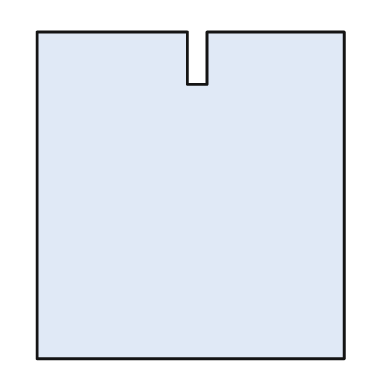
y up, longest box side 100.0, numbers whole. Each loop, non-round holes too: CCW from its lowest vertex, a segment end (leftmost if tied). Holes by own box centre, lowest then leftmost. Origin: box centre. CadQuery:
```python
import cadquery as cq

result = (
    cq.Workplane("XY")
    .moveTo(-47.0, -50.0)
    .lineTo(47.0, -50.0)
    .lineTo(47.0, 50.0)
    .lineTo(5.0, 50.0)
    .lineTo(5.0, 34.0)
    .lineTo(-1.0, 34.0)
    .lineTo(-1.0, 50.0)
    .lineTo(-47.0, 50.0)
    .close()
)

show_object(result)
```